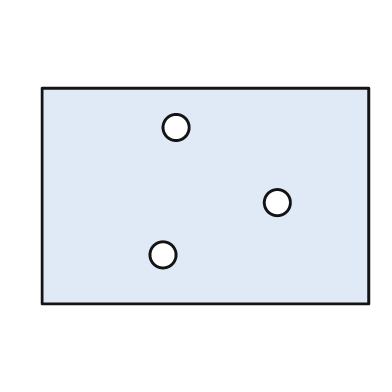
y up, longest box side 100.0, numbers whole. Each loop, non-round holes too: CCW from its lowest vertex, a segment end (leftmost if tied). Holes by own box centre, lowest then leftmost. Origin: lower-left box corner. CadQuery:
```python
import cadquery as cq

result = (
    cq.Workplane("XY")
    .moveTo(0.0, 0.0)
    .lineTo(100.0, 0.0)
    .lineTo(100.0, 66.0)
    .lineTo(0.0, 66.0)
    .close()
    .moveTo(37.0, 15.0)
    .circle(4.0)
    .moveTo(72.0, 31.0)
    .circle(4.0)
    .moveTo(41.0, 54.0)
    .circle(4.0)
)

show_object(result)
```